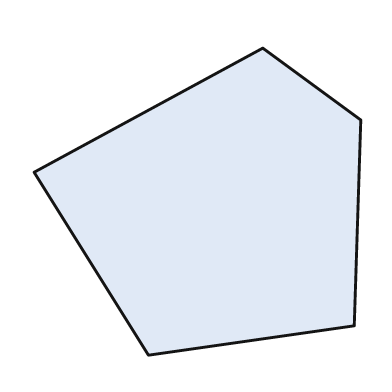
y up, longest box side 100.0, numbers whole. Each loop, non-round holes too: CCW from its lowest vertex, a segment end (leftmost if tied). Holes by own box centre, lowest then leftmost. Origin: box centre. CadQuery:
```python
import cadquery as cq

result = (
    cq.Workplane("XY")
    .moveTo(-15.0, -47.0)
    .lineTo(48.0, -38.0)
    .lineTo(50.0, 25.0)
    .lineTo(20.0, 47.0)
    .lineTo(-50.0, 9.0)
    .close()
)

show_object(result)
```